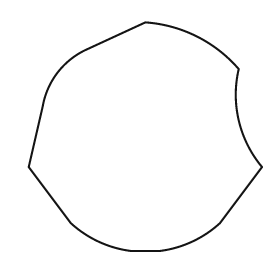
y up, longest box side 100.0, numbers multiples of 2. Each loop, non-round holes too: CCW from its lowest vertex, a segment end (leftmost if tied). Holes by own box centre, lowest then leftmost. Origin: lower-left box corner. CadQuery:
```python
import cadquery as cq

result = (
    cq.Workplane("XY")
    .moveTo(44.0, 0.0)
    .lineTo(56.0, 0.0)
    .threePointArc((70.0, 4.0), (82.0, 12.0))
    .lineTo(100.0, 36.0)
    .threePointArc((90.0, 56.0), (90.0, 78.0))
    .threePointArc((72.0, 92.0), (50.0, 98.0))
    .lineTo(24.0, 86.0)
    .threePointArc((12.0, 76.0), (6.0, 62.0))
    .lineTo(0.0, 36.0)
    .lineTo(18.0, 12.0)
    .threePointArc((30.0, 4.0), (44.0, 0.0))
    .close()
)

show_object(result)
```